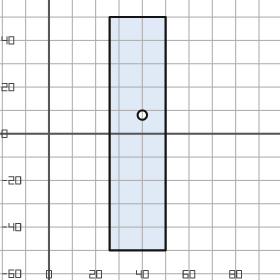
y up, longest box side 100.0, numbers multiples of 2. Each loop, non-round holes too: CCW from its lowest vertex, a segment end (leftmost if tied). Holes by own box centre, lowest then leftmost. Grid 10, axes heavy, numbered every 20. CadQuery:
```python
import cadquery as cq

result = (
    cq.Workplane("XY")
    .moveTo(26.0, -50.0)
    .lineTo(50.0, -50.0)
    .lineTo(50.0, 50.0)
    .lineTo(26.0, 50.0)
    .close()
    .moveTo(40.0, 8.0)
    .circle(2.0)
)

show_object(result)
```